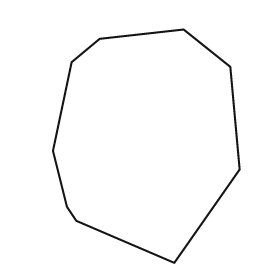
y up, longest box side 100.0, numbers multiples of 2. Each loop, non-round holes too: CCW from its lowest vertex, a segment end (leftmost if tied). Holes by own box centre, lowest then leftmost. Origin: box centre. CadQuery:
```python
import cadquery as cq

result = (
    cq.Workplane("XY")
    .moveTo(12.0, -50.0)
    .lineTo(40.0, -10.0)
    .lineTo(36.0, 34.0)
    .lineTo(16.0, 50.0)
    .lineTo(-20.0, 46.0)
    .lineTo(-32.0, 36.0)
    .lineTo(-40.0, -2.0)
    .lineTo(-34.0, -26.0)
    .lineTo(-30.0, -32.0)
    .close()
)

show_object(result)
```